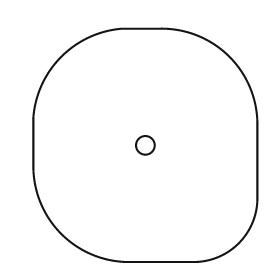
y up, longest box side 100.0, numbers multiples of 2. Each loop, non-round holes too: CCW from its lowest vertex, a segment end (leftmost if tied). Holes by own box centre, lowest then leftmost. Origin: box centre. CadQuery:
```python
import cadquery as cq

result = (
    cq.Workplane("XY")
    .moveTo(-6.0, -50.0)
    .lineTo(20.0, -50.0)
    .threePointArc((40.0, -42.0), (48.0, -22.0))
    .lineTo(48.0, 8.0)
    .threePointArc((36.0, 38.0), (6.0, 50.0))
    .lineTo(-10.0, 50.0)
    .threePointArc((-36.0, 38.0), (-48.0, 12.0))
    .lineTo(-48.0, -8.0)
    .threePointArc((-36.0, -38.0), (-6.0, -50.0))
    .close()
    .moveTo(0.0, 0.0)
    .circle(4.0)
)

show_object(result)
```